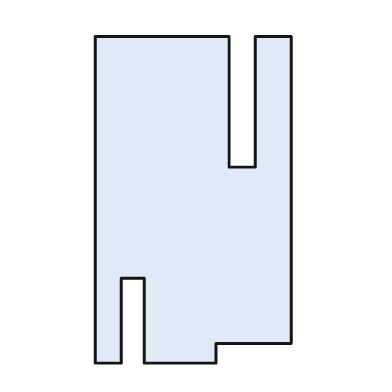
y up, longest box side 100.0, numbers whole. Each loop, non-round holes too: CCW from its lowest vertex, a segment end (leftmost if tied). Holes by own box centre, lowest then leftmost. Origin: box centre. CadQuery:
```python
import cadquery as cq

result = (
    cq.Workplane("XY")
    .moveTo(-30.0, -50.0)
    .lineTo(-22.0, -50.0)
    .lineTo(-22.0, -24.0)
    .lineTo(-15.0, -24.0)
    .lineTo(-15.0, -50.0)
    .lineTo(7.0, -50.0)
    .lineTo(7.0, -44.0)
    .lineTo(30.0, -44.0)
    .lineTo(30.0, 50.0)
    .lineTo(19.0, 50.0)
    .lineTo(19.0, 10.0)
    .lineTo(11.0, 10.0)
    .lineTo(11.0, 50.0)
    .lineTo(-30.0, 50.0)
    .close()
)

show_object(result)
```